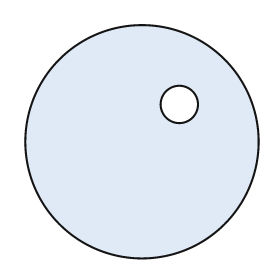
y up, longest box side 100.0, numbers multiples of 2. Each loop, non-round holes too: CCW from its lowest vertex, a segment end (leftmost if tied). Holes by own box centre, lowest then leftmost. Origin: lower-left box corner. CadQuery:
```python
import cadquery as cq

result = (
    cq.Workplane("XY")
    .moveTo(50.0, 50.0)
    .circle(50.0)
    .moveTo(66.0, 66.0)
    .circle(8.0)
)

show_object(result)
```